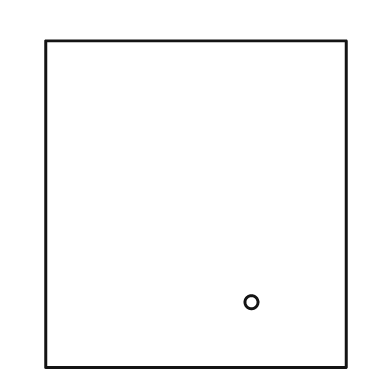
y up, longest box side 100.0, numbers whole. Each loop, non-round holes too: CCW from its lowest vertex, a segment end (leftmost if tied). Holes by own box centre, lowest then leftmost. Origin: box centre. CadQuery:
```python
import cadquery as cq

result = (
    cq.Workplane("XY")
    .moveTo(-46.0, -50.0)
    .lineTo(46.0, -50.0)
    .lineTo(46.0, 50.0)
    .lineTo(-46.0, 50.0)
    .close()
    .moveTo(17.0, -30.0)
    .circle(2.0)
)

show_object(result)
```